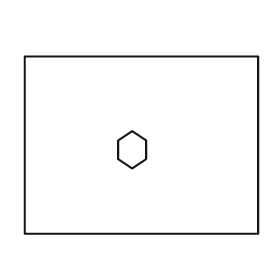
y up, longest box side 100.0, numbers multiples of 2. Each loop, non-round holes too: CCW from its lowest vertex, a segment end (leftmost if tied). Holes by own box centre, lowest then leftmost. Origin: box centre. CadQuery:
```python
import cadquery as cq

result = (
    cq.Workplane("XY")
    .moveTo(-50.0, -38.0)
    .lineTo(50.0, -38.0)
    .lineTo(50.0, 38.0)
    .lineTo(-50.0, 38.0)
    .close()
    .moveTo(-4.0, -10.0)
    .lineTo(2.0, -6.0)
    .lineTo(2.0, 2.0)
    .lineTo(-4.0, 6.0)
    .lineTo(-10.0, 2.0)
    .lineTo(-10.0, -6.0)
    .close()
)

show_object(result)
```